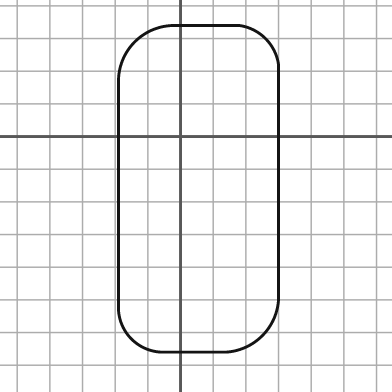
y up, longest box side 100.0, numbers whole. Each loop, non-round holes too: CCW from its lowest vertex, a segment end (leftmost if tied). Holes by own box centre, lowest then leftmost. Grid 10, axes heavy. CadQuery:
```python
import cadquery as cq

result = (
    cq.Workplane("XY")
    .moveTo(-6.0, -66.0)
    .lineTo(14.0, -66.0)
    .threePointArc((25.0, -61.0), (30.0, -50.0))
    .lineTo(30.0, 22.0)
    .threePointArc((26.0, 30.0), (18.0, 34.0))
    .lineTo(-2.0, 34.0)
    .threePointArc((-14.0, 29.0), (-19.0, 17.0))
    .lineTo(-19.0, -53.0)
    .threePointArc((-15.0, -62.0), (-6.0, -66.0))
    .close()
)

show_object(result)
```